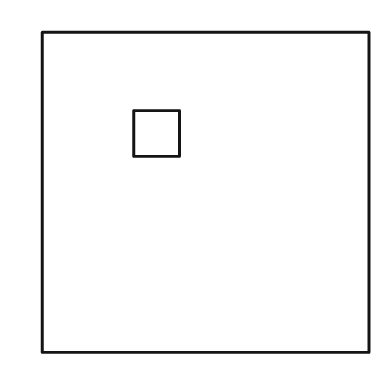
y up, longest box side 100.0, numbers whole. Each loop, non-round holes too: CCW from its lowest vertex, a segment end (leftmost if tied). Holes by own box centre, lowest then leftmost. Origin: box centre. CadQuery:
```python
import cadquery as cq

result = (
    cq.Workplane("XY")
    .moveTo(-50.0, -49.0)
    .lineTo(50.0, -49.0)
    .lineTo(50.0, 49.0)
    .lineTo(-50.0, 49.0)
    .close()
    .moveTo(-22.0, 11.0)
    .lineTo(-8.0, 11.0)
    .lineTo(-8.0, 25.0)
    .lineTo(-22.0, 25.0)
    .close()
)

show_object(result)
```